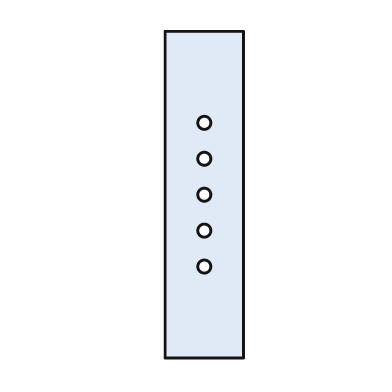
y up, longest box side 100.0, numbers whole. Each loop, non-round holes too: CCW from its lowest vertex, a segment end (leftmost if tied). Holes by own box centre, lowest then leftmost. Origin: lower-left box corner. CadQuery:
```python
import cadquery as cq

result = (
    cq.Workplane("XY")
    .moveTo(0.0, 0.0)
    .lineTo(24.0, 0.0)
    .lineTo(24.0, 100.0)
    .lineTo(0.0, 100.0)
    .close()
    .moveTo(12.0, 28.0)
    .circle(2.0)
    .moveTo(12.0, 39.0)
    .circle(2.0)
    .moveTo(12.0, 50.0)
    .circle(2.0)
    .moveTo(12.0, 61.0)
    .circle(2.0)
    .moveTo(12.0, 72.0)
    .circle(2.0)
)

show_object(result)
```